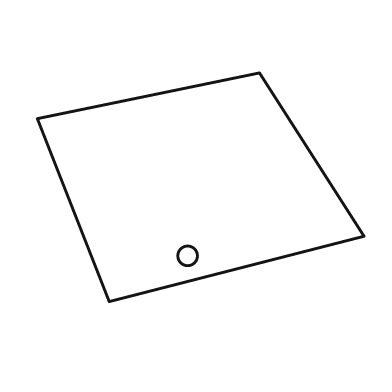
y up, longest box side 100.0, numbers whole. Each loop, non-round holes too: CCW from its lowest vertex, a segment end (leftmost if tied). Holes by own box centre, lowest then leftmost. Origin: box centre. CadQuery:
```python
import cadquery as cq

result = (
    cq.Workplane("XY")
    .moveTo(-28.0, -35.0)
    .lineTo(50.0, -15.0)
    .lineTo(18.0, 35.0)
    .lineTo(-50.0, 21.0)
    .close()
    .moveTo(-4.0, -21.0)
    .circle(3.0)
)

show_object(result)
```